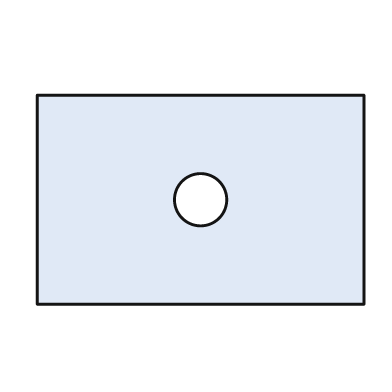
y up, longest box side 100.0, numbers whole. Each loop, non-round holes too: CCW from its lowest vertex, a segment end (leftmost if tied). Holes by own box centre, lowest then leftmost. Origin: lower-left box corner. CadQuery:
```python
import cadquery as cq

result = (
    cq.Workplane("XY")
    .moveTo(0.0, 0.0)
    .lineTo(100.0, 0.0)
    .lineTo(100.0, 64.0)
    .lineTo(0.0, 64.0)
    .close()
    .moveTo(50.0, 32.0)
    .circle(8.0)
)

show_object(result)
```